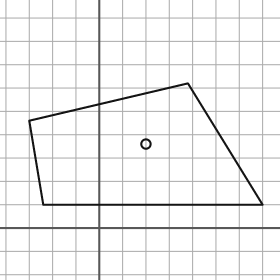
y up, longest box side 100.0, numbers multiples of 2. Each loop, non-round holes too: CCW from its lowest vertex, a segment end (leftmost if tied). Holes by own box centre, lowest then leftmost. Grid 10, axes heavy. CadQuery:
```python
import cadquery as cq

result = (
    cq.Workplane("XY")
    .moveTo(-24.0, 10.0)
    .lineTo(70.0, 10.0)
    .lineTo(38.0, 62.0)
    .lineTo(-30.0, 46.0)
    .close()
    .moveTo(20.0, 36.0)
    .circle(2.0)
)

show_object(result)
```